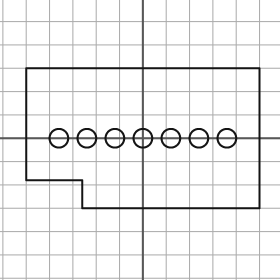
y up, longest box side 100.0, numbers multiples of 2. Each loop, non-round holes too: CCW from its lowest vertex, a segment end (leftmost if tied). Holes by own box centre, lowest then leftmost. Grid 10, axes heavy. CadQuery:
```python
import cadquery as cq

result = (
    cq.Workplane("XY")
    .moveTo(-26.0, -30.0)
    .lineTo(50.0, -30.0)
    .lineTo(50.0, 30.0)
    .lineTo(-50.0, 30.0)
    .lineTo(-50.0, -18.0)
    .lineTo(-26.0, -18.0)
    .close()
    .moveTo(-36.0, 0.0)
    .circle(4.0)
    .moveTo(-24.0, 0.0)
    .circle(4.0)
    .moveTo(-12.0, 0.0)
    .circle(4.0)
    .moveTo(0.0, 0.0)
    .circle(4.0)
    .moveTo(12.0, 0.0)
    .circle(4.0)
    .moveTo(24.0, 0.0)
    .circle(4.0)
    .moveTo(36.0, 0.0)
    .circle(4.0)
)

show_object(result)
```